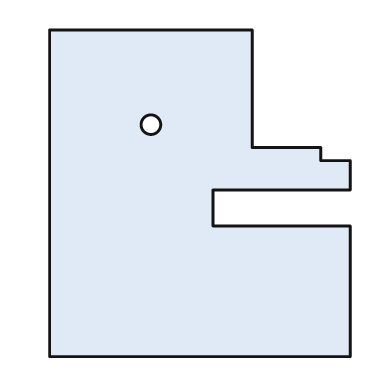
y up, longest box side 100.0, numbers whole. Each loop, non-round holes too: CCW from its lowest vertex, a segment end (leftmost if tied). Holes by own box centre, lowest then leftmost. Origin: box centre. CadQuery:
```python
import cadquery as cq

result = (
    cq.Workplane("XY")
    .moveTo(-46.0, -50.0)
    .lineTo(46.0, -50.0)
    .lineTo(46.0, -10.0)
    .lineTo(4.0, -10.0)
    .lineTo(4.0, 1.0)
    .lineTo(46.0, 1.0)
    .lineTo(46.0, 10.0)
    .lineTo(37.0, 10.0)
    .lineTo(37.0, 14.0)
    .lineTo(16.0, 14.0)
    .lineTo(16.0, 50.0)
    .lineTo(-46.0, 50.0)
    .close()
    .moveTo(-15.0, 21.0)
    .circle(3.0)
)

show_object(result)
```